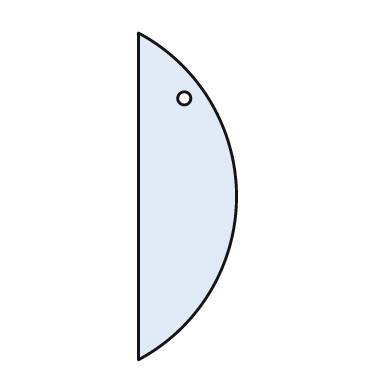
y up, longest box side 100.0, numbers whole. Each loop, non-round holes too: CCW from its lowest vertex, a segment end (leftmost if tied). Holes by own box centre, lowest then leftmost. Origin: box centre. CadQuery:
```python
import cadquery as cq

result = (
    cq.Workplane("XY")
    .moveTo(-15.0, -50.0)
    .threePointArc((15.0, 0.0), (-15.0, 50.0))
    .close()
    .moveTo(-1.0, 30.0)
    .circle(2.0)
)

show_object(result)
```